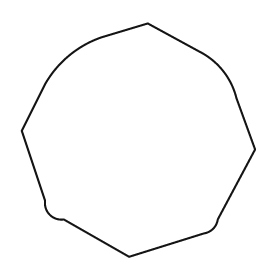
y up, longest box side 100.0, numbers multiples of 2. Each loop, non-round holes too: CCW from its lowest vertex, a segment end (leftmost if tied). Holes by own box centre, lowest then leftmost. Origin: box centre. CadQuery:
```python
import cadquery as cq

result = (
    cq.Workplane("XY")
    .moveTo(-4.0, -50.0)
    .lineTo(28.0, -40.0)
    .threePointArc((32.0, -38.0), (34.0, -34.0))
    .lineTo(50.0, -4.0)
    .lineTo(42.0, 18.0)
    .threePointArc((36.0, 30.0), (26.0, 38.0))
    .lineTo(4.0, 50.0)
    .lineTo(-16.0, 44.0)
    .threePointArc((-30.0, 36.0), (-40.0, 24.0))
    .lineTo(-50.0, 4.0)
    .lineTo(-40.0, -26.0)
    .threePointArc((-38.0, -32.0), (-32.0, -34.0))
    .close()
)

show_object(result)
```